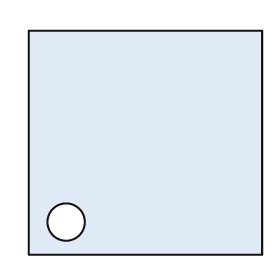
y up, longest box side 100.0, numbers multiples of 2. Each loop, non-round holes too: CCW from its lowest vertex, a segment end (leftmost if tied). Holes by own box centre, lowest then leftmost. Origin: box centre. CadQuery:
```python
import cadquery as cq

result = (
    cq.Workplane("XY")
    .moveTo(-50.0, -48.0)
    .lineTo(50.0, -48.0)
    .lineTo(50.0, 48.0)
    .lineTo(-50.0, 48.0)
    .close()
    .moveTo(-34.0, -34.0)
    .circle(8.0)
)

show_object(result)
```